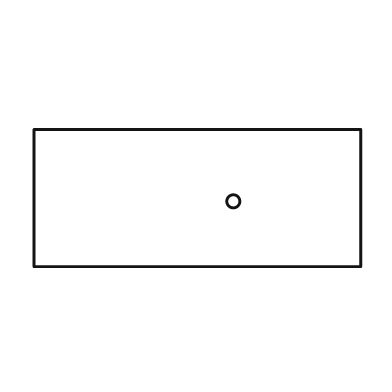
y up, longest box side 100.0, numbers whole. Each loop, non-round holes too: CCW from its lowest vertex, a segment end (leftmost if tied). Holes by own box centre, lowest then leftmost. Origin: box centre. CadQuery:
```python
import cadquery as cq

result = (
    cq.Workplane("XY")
    .moveTo(-50.0, -21.0)
    .lineTo(50.0, -21.0)
    .lineTo(50.0, 21.0)
    .lineTo(-50.0, 21.0)
    .close()
    .moveTo(11.0, -1.0)
    .circle(2.0)
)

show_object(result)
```